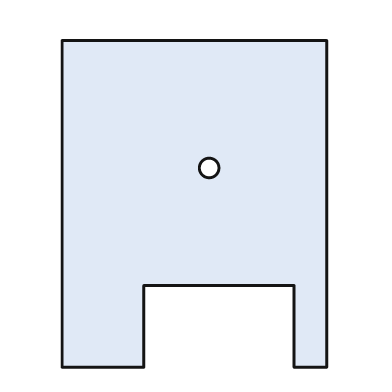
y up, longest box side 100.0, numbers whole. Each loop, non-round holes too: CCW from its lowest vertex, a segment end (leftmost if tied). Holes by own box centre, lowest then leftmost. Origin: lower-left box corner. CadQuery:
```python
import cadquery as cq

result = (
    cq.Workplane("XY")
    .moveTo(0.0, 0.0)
    .lineTo(25.0, 0.0)
    .lineTo(25.0, 25.0)
    .lineTo(71.0, 25.0)
    .lineTo(71.0, 0.0)
    .lineTo(81.0, 0.0)
    .lineTo(81.0, 100.0)
    .lineTo(0.0, 100.0)
    .close()
    .moveTo(45.0, 61.0)
    .circle(3.0)
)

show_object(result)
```